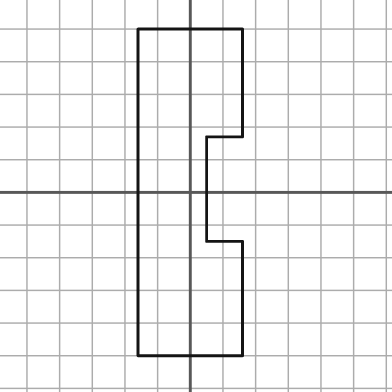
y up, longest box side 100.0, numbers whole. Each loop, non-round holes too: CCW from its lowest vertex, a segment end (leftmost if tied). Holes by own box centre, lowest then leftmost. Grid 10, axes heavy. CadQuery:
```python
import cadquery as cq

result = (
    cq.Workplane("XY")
    .moveTo(-16.0, -50.0)
    .lineTo(16.0, -50.0)
    .lineTo(16.0, -15.0)
    .lineTo(5.0, -15.0)
    .lineTo(5.0, 17.0)
    .lineTo(16.0, 17.0)
    .lineTo(16.0, 50.0)
    .lineTo(-16.0, 50.0)
    .close()
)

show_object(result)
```